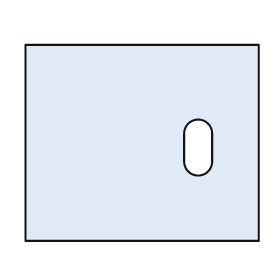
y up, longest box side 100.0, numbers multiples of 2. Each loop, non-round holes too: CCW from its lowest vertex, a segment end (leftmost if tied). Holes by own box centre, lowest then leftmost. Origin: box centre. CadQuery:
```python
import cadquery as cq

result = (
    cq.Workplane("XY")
    .moveTo(-50.0, -42.0)
    .lineTo(50.0, -42.0)
    .lineTo(50.0, 42.0)
    .lineTo(-50.0, 42.0)
    .close()
    .moveTo(18.0, -8.0)
    .threePointArc((24.0, -14.0), (30.0, -8.0))
    .lineTo(30.0, 4.0)
    .threePointArc((24.0, 10.0), (18.0, 4.0))
    .close()
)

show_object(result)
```